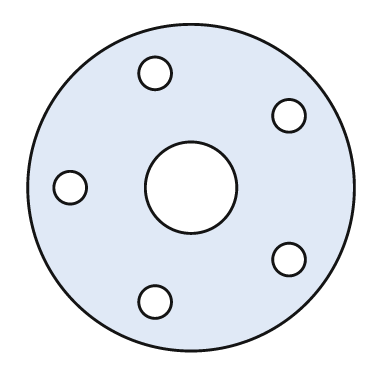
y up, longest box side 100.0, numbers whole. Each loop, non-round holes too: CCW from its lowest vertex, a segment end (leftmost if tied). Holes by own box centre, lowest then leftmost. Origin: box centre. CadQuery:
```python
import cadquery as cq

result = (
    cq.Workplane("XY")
    .moveTo(0.0, 0.0)
    .circle(50.0)
    .moveTo(-11.0, -35.0)
    .circle(5.0)
    .moveTo(30.0, -22.0)
    .circle(5.0)
    .moveTo(-37.0, 0.0)
    .circle(5.0)
    .moveTo(0.0, 0.0)
    .circle(14.0)
    .moveTo(30.0, 22.0)
    .circle(5.0)
    .moveTo(-11.0, 35.0)
    .circle(5.0)
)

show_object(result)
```